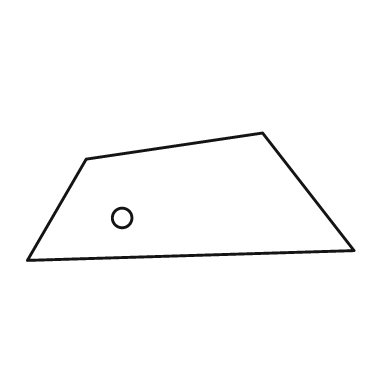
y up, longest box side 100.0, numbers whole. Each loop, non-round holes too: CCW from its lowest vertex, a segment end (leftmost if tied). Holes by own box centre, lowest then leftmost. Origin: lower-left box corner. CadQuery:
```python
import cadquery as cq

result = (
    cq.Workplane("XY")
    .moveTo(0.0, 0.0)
    .lineTo(100.0, 3.0)
    .lineTo(72.0, 39.0)
    .lineTo(18.0, 31.0)
    .close()
    .moveTo(29.0, 13.0)
    .circle(3.0)
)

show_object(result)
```